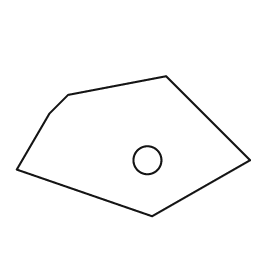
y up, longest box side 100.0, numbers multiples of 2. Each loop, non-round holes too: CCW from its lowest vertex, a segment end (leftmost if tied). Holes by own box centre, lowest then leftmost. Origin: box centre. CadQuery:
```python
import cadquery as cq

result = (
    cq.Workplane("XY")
    .moveTo(8.0, -30.0)
    .lineTo(50.0, -6.0)
    .lineTo(14.0, 30.0)
    .lineTo(-28.0, 22.0)
    .lineTo(-36.0, 14.0)
    .lineTo(-50.0, -10.0)
    .close()
    .moveTo(6.0, -6.0)
    .circle(6.0)
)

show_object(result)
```